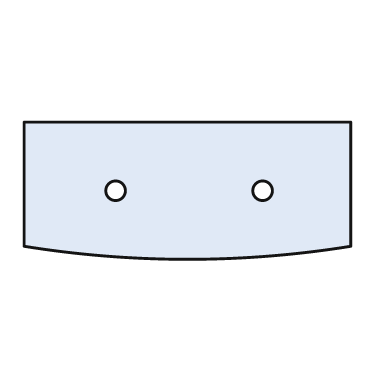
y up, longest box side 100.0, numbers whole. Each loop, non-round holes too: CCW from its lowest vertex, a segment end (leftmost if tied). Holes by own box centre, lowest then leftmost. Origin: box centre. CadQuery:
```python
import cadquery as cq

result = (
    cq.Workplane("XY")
    .moveTo(-50.0, -17.0)
    .threePointArc((0.0, -21.0), (50.0, -17.0))
    .lineTo(50.0, 21.0)
    .lineTo(-50.0, 21.0)
    .close()
    .moveTo(-22.0, 0.0)
    .circle(3.0)
    .moveTo(23.0, 0.0)
    .circle(3.0)
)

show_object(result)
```